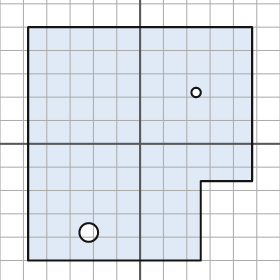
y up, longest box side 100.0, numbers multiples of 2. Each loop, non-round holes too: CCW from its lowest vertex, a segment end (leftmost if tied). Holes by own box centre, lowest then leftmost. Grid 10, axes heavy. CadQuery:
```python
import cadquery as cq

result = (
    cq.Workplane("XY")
    .moveTo(-48.0, -50.0)
    .lineTo(26.0, -50.0)
    .lineTo(26.0, -16.0)
    .lineTo(48.0, -16.0)
    .lineTo(48.0, 50.0)
    .lineTo(-48.0, 50.0)
    .close()
    .moveTo(-22.0, -38.0)
    .circle(4.0)
    .moveTo(24.0, 22.0)
    .circle(2.0)
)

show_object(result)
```